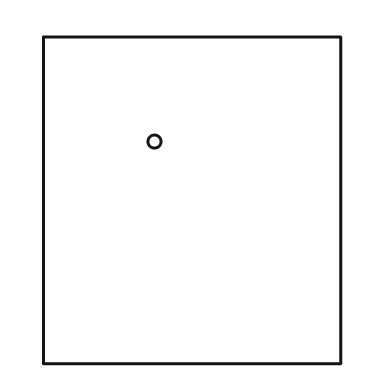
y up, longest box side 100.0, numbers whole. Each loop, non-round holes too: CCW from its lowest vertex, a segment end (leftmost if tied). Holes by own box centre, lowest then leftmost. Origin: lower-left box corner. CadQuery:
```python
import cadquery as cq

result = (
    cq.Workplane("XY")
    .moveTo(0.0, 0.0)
    .lineTo(91.0, 0.0)
    .lineTo(91.0, 100.0)
    .lineTo(0.0, 100.0)
    .close()
    .moveTo(34.0, 68.0)
    .circle(2.0)
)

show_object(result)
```